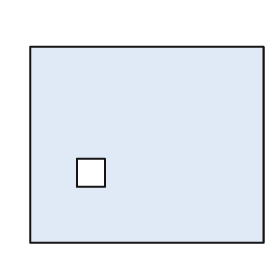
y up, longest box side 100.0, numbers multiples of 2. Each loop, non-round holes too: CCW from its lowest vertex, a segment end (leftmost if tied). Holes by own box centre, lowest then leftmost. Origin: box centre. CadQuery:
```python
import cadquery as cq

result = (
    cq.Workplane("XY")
    .moveTo(-50.0, -42.0)
    .lineTo(50.0, -42.0)
    .lineTo(50.0, 42.0)
    .lineTo(-50.0, 42.0)
    .close()
    .moveTo(-30.0, -18.0)
    .lineTo(-18.0, -18.0)
    .lineTo(-18.0, -6.0)
    .lineTo(-30.0, -6.0)
    .close()
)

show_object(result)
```